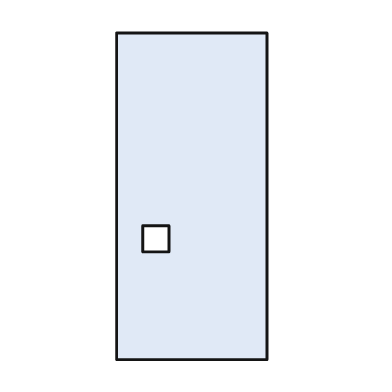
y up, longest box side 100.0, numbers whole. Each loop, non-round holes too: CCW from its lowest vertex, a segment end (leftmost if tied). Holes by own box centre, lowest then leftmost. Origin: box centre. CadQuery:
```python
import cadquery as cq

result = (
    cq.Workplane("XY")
    .moveTo(-23.0, -50.0)
    .lineTo(23.0, -50.0)
    .lineTo(23.0, 50.0)
    .lineTo(-23.0, 50.0)
    .close()
    .moveTo(-15.0, -17.0)
    .lineTo(-7.0, -17.0)
    .lineTo(-7.0, -9.0)
    .lineTo(-15.0, -9.0)
    .close()
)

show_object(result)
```